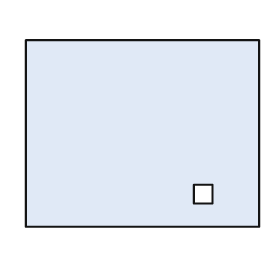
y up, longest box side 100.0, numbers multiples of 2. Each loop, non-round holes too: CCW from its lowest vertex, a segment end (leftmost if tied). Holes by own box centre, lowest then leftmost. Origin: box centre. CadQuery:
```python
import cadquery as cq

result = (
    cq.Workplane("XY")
    .moveTo(-50.0, -40.0)
    .lineTo(50.0, -40.0)
    .lineTo(50.0, 40.0)
    .lineTo(-50.0, 40.0)
    .close()
    .moveTo(22.0, -30.0)
    .lineTo(30.0, -30.0)
    .lineTo(30.0, -22.0)
    .lineTo(22.0, -22.0)
    .close()
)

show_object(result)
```